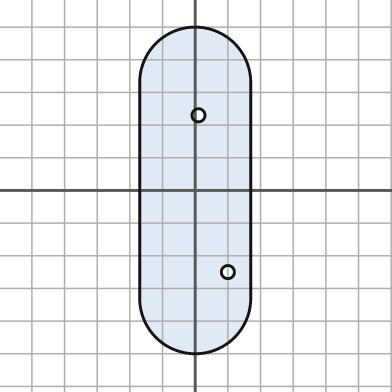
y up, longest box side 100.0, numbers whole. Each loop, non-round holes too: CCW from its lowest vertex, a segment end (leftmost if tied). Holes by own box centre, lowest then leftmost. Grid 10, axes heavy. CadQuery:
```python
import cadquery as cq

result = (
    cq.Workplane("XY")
    .moveTo(-17.0, -33.0)
    .threePointArc((0.0, -50.0), (17.0, -33.0))
    .lineTo(17.0, 33.0)
    .threePointArc((0.0, 50.0), (-17.0, 33.0))
    .close()
    .moveTo(10.0, -25.0)
    .circle(2.0)
    .moveTo(1.0, 23.0)
    .circle(2.0)
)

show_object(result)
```